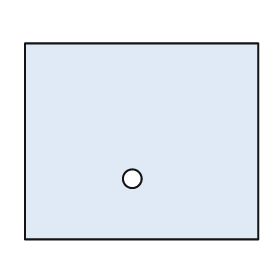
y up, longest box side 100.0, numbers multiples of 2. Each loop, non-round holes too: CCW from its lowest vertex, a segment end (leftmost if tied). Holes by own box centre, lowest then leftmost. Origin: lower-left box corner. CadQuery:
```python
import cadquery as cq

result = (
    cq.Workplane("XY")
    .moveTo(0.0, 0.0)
    .lineTo(100.0, 0.0)
    .lineTo(100.0, 84.0)
    .lineTo(0.0, 84.0)
    .close()
    .moveTo(46.0, 26.0)
    .circle(4.0)
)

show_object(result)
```